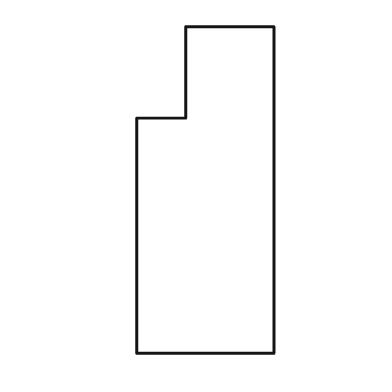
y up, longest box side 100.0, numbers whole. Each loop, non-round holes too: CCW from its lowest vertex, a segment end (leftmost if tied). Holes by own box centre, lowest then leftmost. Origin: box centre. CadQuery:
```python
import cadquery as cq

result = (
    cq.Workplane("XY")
    .moveTo(-21.0, -50.0)
    .lineTo(21.0, -50.0)
    .lineTo(21.0, 50.0)
    .lineTo(-6.0, 50.0)
    .lineTo(-6.0, 22.0)
    .lineTo(-21.0, 22.0)
    .close()
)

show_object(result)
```